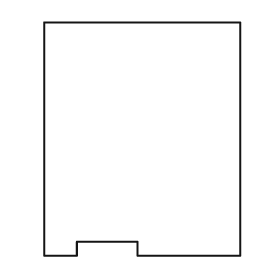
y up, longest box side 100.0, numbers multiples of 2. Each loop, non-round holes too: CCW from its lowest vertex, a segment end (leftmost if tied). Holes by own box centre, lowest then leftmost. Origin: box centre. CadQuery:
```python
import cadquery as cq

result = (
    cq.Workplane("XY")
    .moveTo(-42.0, -50.0)
    .lineTo(-28.0, -50.0)
    .lineTo(-28.0, -44.0)
    .lineTo(-2.0, -44.0)
    .lineTo(-2.0, -50.0)
    .lineTo(42.0, -50.0)
    .lineTo(42.0, 50.0)
    .lineTo(-42.0, 50.0)
    .close()
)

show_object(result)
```